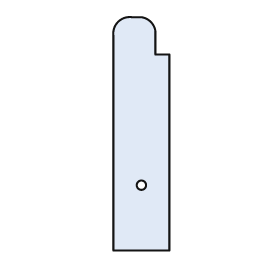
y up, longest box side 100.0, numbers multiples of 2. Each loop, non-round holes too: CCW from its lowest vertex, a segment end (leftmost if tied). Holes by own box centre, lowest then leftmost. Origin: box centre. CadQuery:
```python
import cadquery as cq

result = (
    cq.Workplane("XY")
    .moveTo(-12.0, -50.0)
    .lineTo(12.0, -50.0)
    .lineTo(12.0, 34.0)
    .lineTo(6.0, 34.0)
    .lineTo(6.0, 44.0)
    .threePointArc((4.0, 48.0), (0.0, 50.0))
    .lineTo(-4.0, 50.0)
    .threePointArc((-10.0, 48.0), (-12.0, 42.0))
    .close()
    .moveTo(0.0, -22.0)
    .circle(2.0)
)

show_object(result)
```